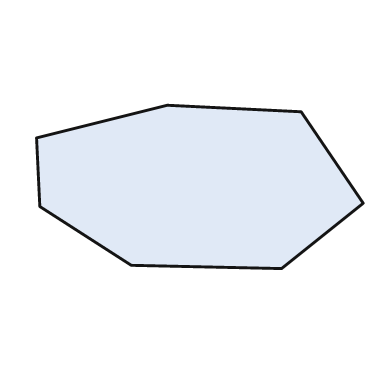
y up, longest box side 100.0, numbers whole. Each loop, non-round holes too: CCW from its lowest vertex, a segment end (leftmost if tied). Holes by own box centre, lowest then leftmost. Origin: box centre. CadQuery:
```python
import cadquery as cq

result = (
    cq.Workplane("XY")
    .moveTo(25.0, -25.0)
    .lineTo(50.0, -5.0)
    .lineTo(31.0, 23.0)
    .lineTo(-10.0, 25.0)
    .lineTo(-50.0, 15.0)
    .lineTo(-49.0, -6.0)
    .lineTo(-21.0, -24.0)
    .close()
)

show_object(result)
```